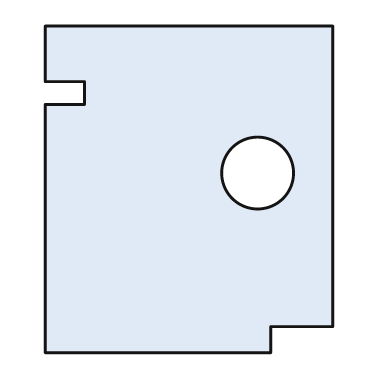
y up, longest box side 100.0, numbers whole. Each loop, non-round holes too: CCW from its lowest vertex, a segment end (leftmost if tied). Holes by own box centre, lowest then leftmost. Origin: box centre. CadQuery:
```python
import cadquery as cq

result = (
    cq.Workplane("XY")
    .moveTo(-44.0, -50.0)
    .lineTo(25.0, -50.0)
    .lineTo(25.0, -42.0)
    .lineTo(44.0, -42.0)
    .lineTo(44.0, 50.0)
    .lineTo(-44.0, 50.0)
    .lineTo(-44.0, 33.0)
    .lineTo(-32.0, 33.0)
    .lineTo(-32.0, 26.0)
    .lineTo(-44.0, 26.0)
    .close()
    .moveTo(21.0, 5.0)
    .circle(11.0)
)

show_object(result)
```